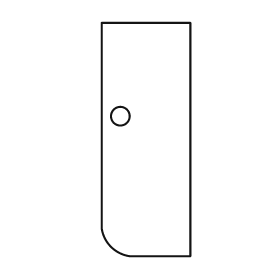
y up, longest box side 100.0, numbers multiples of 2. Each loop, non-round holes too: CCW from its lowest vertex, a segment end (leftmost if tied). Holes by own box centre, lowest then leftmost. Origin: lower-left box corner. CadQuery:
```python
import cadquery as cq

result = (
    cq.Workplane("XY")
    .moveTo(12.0, 0.0)
    .lineTo(38.0, 0.0)
    .lineTo(38.0, 100.0)
    .lineTo(0.0, 100.0)
    .lineTo(0.0, 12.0)
    .threePointArc((4.0, 4.0), (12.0, 0.0))
    .close()
    .moveTo(8.0, 60.0)
    .circle(4.0)
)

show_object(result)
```